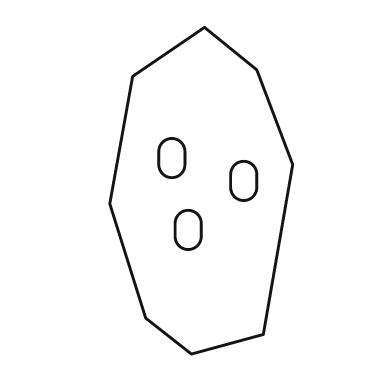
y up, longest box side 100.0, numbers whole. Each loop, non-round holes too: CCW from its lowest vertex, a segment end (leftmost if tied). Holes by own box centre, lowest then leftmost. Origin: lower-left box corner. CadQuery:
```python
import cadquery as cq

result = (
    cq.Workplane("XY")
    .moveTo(25.0, 0.0)
    .lineTo(47.0, 6.0)
    .lineTo(56.0, 58.0)
    .lineTo(45.0, 87.0)
    .lineTo(29.0, 100.0)
    .lineTo(7.0, 85.0)
    .lineTo(0.0, 46.0)
    .lineTo(11.0, 11.0)
    .close()
    .moveTo(20.0, 36.0)
    .threePointArc((24.0, 32.0), (28.0, 36.0))
    .lineTo(28.0, 40.0)
    .threePointArc((24.0, 44.0), (20.0, 40.0))
    .close()
    .moveTo(37.0, 51.0)
    .threePointArc((41.0, 47.0), (45.0, 51.0))
    .lineTo(45.0, 55.0)
    .threePointArc((41.0, 59.0), (37.0, 55.0))
    .close()
    .moveTo(15.0, 58.0)
    .threePointArc((19.0, 54.0), (23.0, 58.0))
    .lineTo(23.0, 62.0)
    .threePointArc((19.0, 66.0), (15.0, 62.0))
    .close()
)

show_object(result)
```